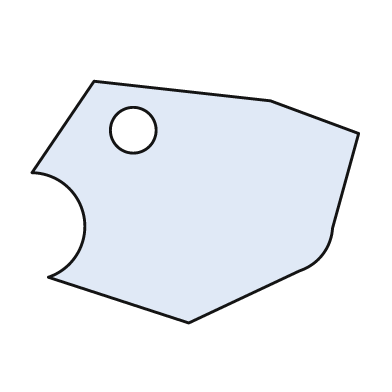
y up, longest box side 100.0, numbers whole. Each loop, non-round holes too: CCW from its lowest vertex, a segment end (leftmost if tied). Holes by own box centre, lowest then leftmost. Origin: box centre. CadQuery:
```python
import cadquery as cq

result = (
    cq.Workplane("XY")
    .moveTo(-2.0, -37.0)
    .lineTo(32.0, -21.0)
    .threePointArc((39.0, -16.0), (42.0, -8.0))
    .lineTo(50.0, 21.0)
    .lineTo(23.0, 31.0)
    .lineTo(-31.0, 37.0)
    .lineTo(-50.0, 9.0)
    .threePointArc((-34.0, -5.0), (-45.0, -23.0))
    .close()
    .moveTo(-19.0, 22.0)
    .circle(7.0)
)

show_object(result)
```